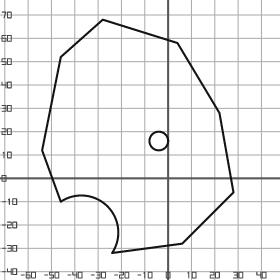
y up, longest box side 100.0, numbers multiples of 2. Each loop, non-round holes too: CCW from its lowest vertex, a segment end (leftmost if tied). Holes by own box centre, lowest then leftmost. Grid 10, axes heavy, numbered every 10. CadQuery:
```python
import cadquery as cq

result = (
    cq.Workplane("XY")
    .moveTo(-24.0, -32.0)
    .lineTo(6.0, -28.0)
    .lineTo(28.0, -6.0)
    .lineTo(22.0, 28.0)
    .lineTo(4.0, 58.0)
    .lineTo(-28.0, 68.0)
    .lineTo(-46.0, 52.0)
    .lineTo(-54.0, 12.0)
    .lineTo(-46.0, -10.0)
    .threePointArc((-26.0, -12.0), (-24.0, -32.0))
    .close()
    .moveTo(-4.0, 16.0)
    .circle(4.0)
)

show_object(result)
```